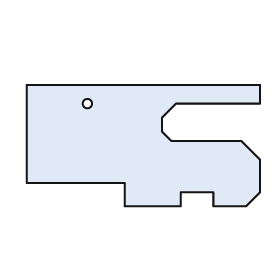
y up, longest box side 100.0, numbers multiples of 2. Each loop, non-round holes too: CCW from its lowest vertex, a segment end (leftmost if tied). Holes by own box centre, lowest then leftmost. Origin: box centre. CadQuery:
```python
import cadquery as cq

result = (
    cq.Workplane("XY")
    .moveTo(-8.0, -26.0)
    .lineTo(16.0, -26.0)
    .lineTo(16.0, -20.0)
    .lineTo(30.0, -20.0)
    .lineTo(30.0, -26.0)
    .lineTo(44.0, -26.0)
    .lineTo(50.0, -20.0)
    .lineTo(50.0, -6.0)
    .lineTo(42.0, 2.0)
    .lineTo(12.0, 2.0)
    .lineTo(8.0, 6.0)
    .lineTo(8.0, 12.0)
    .lineTo(14.0, 18.0)
    .lineTo(50.0, 18.0)
    .lineTo(50.0, 26.0)
    .lineTo(-50.0, 26.0)
    .lineTo(-50.0, -16.0)
    .lineTo(-8.0, -16.0)
    .close()
    .moveTo(-24.0, 18.0)
    .circle(2.0)
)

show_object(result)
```